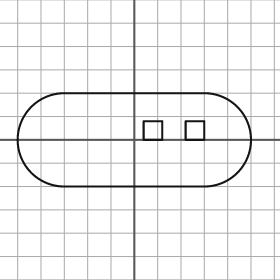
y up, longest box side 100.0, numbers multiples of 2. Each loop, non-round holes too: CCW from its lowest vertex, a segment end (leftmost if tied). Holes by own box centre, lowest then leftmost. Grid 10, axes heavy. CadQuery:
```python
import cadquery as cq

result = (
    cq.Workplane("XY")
    .moveTo(-30.0, -20.0)
    .lineTo(30.0, -20.0)
    .threePointArc((50.0, 0.0), (30.0, 20.0))
    .lineTo(-30.0, 20.0)
    .threePointArc((-50.0, 0.0), (-30.0, -20.0))
    .close()
    .moveTo(4.0, 0.0)
    .lineTo(12.0, 0.0)
    .lineTo(12.0, 8.0)
    .lineTo(4.0, 8.0)
    .close()
    .moveTo(22.0, 0.0)
    .lineTo(30.0, 0.0)
    .lineTo(30.0, 8.0)
    .lineTo(22.0, 8.0)
    .close()
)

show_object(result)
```